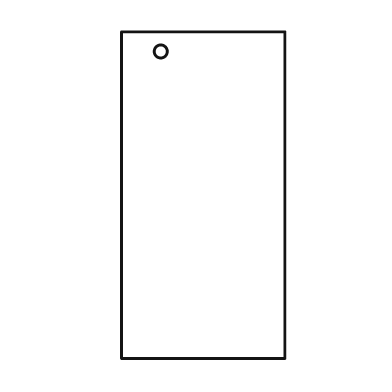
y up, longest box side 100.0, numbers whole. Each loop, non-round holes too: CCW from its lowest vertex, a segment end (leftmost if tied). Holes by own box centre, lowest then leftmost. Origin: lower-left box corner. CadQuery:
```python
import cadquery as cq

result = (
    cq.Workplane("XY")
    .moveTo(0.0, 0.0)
    .lineTo(50.0, 0.0)
    .lineTo(50.0, 100.0)
    .lineTo(0.0, 100.0)
    .close()
    .moveTo(12.0, 94.0)
    .circle(2.0)
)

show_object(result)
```